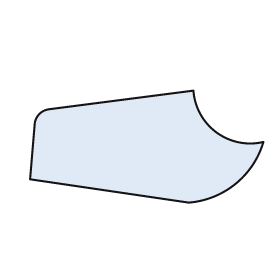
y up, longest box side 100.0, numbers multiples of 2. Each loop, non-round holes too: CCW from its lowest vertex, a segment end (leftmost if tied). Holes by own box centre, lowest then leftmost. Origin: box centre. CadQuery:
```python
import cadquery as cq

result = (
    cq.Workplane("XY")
    .moveTo(18.0, -24.0)
    .threePointArc((38.0, -16.0), (50.0, 2.0))
    .threePointArc((30.0, 6.0), (20.0, 24.0))
    .lineTo(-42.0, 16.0)
    .threePointArc((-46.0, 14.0), (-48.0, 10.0))
    .lineTo(-50.0, -14.0)
    .close()
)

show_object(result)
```